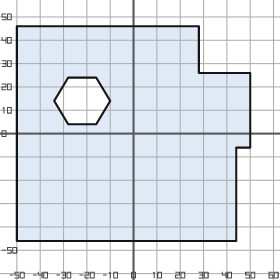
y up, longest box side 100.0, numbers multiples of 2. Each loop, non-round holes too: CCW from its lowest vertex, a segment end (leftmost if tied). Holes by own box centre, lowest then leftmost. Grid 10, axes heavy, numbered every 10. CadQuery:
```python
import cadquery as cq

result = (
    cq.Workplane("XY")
    .moveTo(-50.0, -46.0)
    .lineTo(44.0, -46.0)
    .lineTo(44.0, -6.0)
    .lineTo(50.0, -6.0)
    .lineTo(50.0, 26.0)
    .lineTo(28.0, 26.0)
    .lineTo(28.0, 46.0)
    .lineTo(-50.0, 46.0)
    .close()
    .moveTo(-28.0, 4.0)
    .lineTo(-16.0, 4.0)
    .lineTo(-10.0, 14.0)
    .lineTo(-16.0, 24.0)
    .lineTo(-28.0, 24.0)
    .lineTo(-34.0, 14.0)
    .close()
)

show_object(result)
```